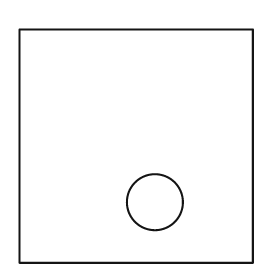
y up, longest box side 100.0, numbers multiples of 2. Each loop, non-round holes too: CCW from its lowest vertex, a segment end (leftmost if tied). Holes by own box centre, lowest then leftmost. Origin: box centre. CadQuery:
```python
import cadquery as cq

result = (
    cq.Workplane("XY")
    .moveTo(-50.0, -50.0)
    .lineTo(50.0, -50.0)
    .lineTo(50.0, 50.0)
    .lineTo(-50.0, 50.0)
    .close()
    .moveTo(8.0, -24.0)
    .circle(12.0)
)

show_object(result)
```